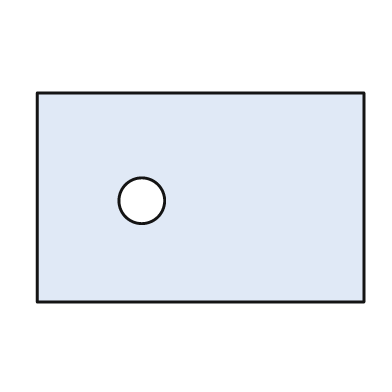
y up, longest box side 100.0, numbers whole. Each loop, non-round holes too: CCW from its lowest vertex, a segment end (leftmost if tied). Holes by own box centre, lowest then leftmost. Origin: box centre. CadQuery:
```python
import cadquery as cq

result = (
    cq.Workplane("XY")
    .moveTo(-50.0, -32.0)
    .lineTo(50.0, -32.0)
    .lineTo(50.0, 32.0)
    .lineTo(-50.0, 32.0)
    .close()
    .moveTo(-18.0, -1.0)
    .circle(7.0)
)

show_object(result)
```